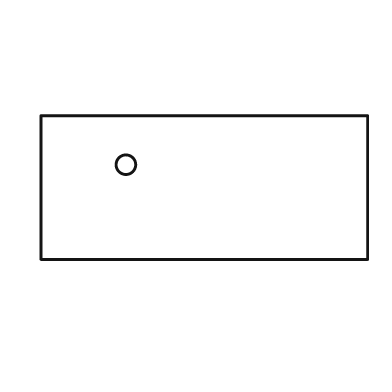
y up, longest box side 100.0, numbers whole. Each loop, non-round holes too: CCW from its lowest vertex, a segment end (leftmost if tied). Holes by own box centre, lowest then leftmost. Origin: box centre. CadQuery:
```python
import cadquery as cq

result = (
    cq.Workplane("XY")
    .moveTo(-50.0, -22.0)
    .lineTo(50.0, -22.0)
    .lineTo(50.0, 22.0)
    .lineTo(-50.0, 22.0)
    .close()
    .moveTo(-24.0, 7.0)
    .circle(3.0)
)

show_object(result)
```